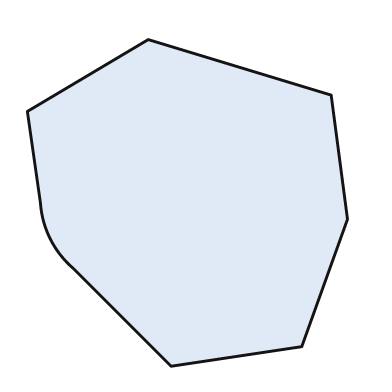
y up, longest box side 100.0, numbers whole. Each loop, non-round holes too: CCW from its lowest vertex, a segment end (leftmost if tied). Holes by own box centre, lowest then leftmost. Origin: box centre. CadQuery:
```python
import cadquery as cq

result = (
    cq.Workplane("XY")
    .moveTo(-5.0, -50.0)
    .lineTo(35.0, -44.0)
    .lineTo(49.0, -5.0)
    .lineTo(44.0, 33.0)
    .lineTo(-12.0, 50.0)
    .lineTo(-49.0, 28.0)
    .lineTo(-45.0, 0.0)
    .threePointArc((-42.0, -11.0), (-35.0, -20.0))
    .close()
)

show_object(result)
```